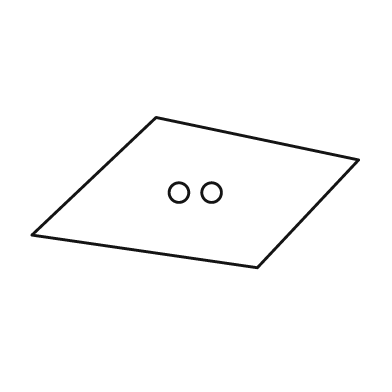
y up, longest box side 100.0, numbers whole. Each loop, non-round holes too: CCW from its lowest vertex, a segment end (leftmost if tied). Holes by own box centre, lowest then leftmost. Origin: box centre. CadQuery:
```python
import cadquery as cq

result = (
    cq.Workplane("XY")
    .moveTo(19.0, -23.0)
    .lineTo(50.0, 10.0)
    .lineTo(-12.0, 23.0)
    .lineTo(-50.0, -13.0)
    .close()
    .moveTo(-5.0, 0.0)
    .circle(3.0)
    .moveTo(5.0, 0.0)
    .circle(3.0)
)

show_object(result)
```